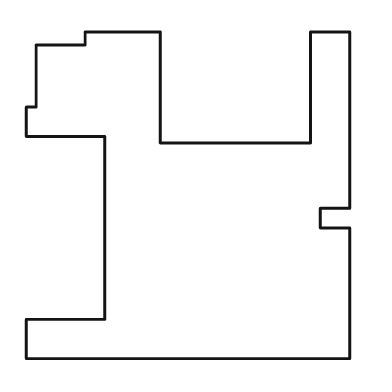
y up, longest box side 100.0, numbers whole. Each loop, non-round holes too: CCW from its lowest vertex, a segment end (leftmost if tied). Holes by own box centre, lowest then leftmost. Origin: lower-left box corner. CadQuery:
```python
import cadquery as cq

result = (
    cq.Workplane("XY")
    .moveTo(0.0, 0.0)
    .lineTo(99.0, 0.0)
    .lineTo(99.0, 40.0)
    .lineTo(90.0, 40.0)
    .lineTo(90.0, 46.0)
    .lineTo(99.0, 46.0)
    .lineTo(99.0, 100.0)
    .lineTo(87.0, 100.0)
    .lineTo(87.0, 66.0)
    .lineTo(41.0, 66.0)
    .lineTo(41.0, 100.0)
    .lineTo(18.0, 100.0)
    .lineTo(18.0, 96.0)
    .lineTo(3.0, 96.0)
    .lineTo(3.0, 77.0)
    .lineTo(0.0, 77.0)
    .lineTo(0.0, 68.0)
    .lineTo(24.0, 68.0)
    .lineTo(24.0, 12.0)
    .lineTo(0.0, 12.0)
    .close()
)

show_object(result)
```